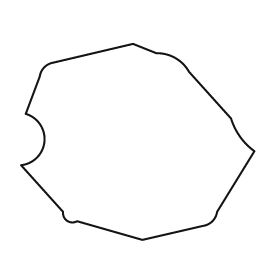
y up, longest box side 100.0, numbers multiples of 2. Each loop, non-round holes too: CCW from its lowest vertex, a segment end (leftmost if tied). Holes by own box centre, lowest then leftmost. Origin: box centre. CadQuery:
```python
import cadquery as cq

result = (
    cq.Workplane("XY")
    .moveTo(2.0, -42.0)
    .lineTo(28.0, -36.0)
    .threePointArc((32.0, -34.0), (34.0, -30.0))
    .lineTo(50.0, -4.0)
    .threePointArc((44.0, 2.0), (40.0, 10.0))
    .lineTo(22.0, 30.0)
    .threePointArc((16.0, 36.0), (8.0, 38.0))
    .lineTo(-2.0, 42.0)
    .lineTo(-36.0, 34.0)
    .threePointArc((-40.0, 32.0), (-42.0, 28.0))
    .lineTo(-48.0, 12.0)
    .threePointArc((-40.0, 0.0), (-50.0, -10.0))
    .lineTo(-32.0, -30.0)
    .threePointArc((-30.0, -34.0), (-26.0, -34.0))
    .close()
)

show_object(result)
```